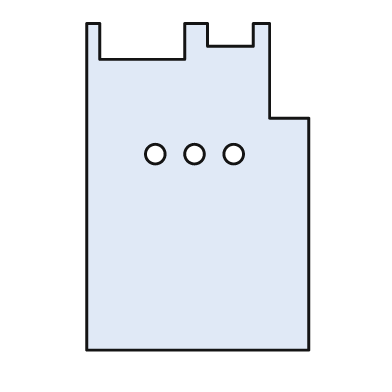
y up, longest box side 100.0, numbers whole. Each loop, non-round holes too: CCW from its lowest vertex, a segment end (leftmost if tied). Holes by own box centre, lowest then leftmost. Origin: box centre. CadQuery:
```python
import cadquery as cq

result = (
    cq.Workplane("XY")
    .moveTo(-34.0, -50.0)
    .lineTo(34.0, -50.0)
    .lineTo(34.0, 21.0)
    .lineTo(22.0, 21.0)
    .lineTo(22.0, 50.0)
    .lineTo(17.0, 50.0)
    .lineTo(17.0, 43.0)
    .lineTo(3.0, 43.0)
    .lineTo(3.0, 50.0)
    .lineTo(-4.0, 50.0)
    .lineTo(-4.0, 39.0)
    .lineTo(-30.0, 39.0)
    .lineTo(-30.0, 50.0)
    .lineTo(-34.0, 50.0)
    .close()
    .moveTo(-13.0, 10.0)
    .circle(3.0)
    .moveTo(-1.0, 10.0)
    .circle(3.0)
    .moveTo(11.0, 10.0)
    .circle(3.0)
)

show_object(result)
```